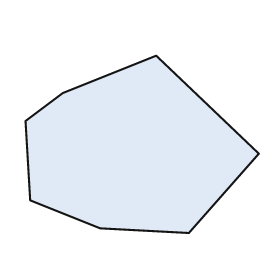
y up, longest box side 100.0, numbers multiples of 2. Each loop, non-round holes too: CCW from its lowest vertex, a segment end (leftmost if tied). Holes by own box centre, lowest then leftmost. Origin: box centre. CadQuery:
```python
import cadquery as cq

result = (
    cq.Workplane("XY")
    .moveTo(20.0, -38.0)
    .lineTo(50.0, -4.0)
    .lineTo(6.0, 38.0)
    .lineTo(-34.0, 22.0)
    .lineTo(-50.0, 10.0)
    .lineTo(-48.0, -24.0)
    .lineTo(-18.0, -36.0)
    .close()
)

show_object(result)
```